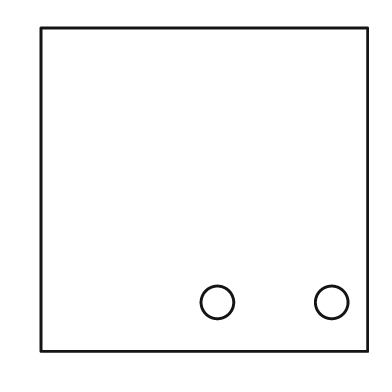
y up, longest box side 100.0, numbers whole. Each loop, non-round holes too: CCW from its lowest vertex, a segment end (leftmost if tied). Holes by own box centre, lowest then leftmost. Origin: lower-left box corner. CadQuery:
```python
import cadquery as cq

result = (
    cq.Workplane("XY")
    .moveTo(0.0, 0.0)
    .lineTo(100.0, 0.0)
    .lineTo(100.0, 99.0)
    .lineTo(0.0, 99.0)
    .close()
    .moveTo(54.0, 15.0)
    .circle(5.0)
    .moveTo(89.0, 15.0)
    .circle(5.0)
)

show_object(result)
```